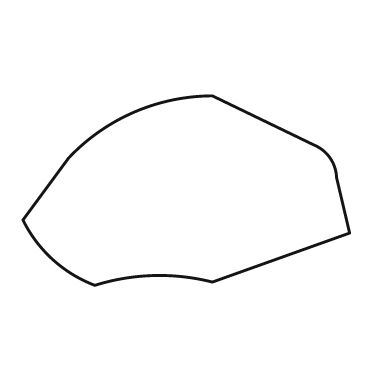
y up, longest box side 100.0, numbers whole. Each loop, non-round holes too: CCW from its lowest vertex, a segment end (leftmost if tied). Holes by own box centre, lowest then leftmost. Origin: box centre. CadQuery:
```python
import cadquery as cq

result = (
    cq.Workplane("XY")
    .moveTo(-28.0, -29.0)
    .threePointArc((-10.0, -26.0), (8.0, -28.0))
    .lineTo(50.0, -13.0)
    .lineTo(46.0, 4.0)
    .threePointArc((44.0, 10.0), (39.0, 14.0))
    .lineTo(8.0, 29.0)
    .threePointArc((-16.0, 24.0), (-36.0, 10.0))
    .lineTo(-50.0, -9.0)
    .threePointArc((-41.0, -21.0), (-28.0, -29.0))
    .close()
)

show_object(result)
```